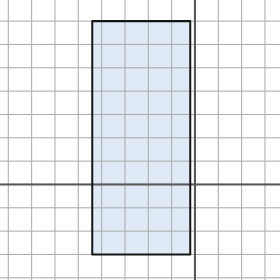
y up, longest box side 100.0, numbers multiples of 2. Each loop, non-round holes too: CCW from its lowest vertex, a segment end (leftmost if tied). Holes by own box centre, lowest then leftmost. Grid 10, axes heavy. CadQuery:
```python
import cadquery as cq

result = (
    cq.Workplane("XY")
    .moveTo(-44.0, -30.0)
    .lineTo(-2.0, -30.0)
    .lineTo(-2.0, 70.0)
    .lineTo(-44.0, 70.0)
    .close()
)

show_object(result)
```